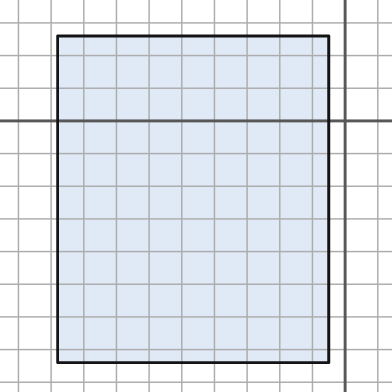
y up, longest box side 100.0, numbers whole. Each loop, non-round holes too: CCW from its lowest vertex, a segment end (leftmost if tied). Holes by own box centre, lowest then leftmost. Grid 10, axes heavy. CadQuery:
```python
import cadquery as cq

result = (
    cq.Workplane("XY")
    .moveTo(-88.0, -74.0)
    .lineTo(-5.0, -74.0)
    .lineTo(-5.0, 26.0)
    .lineTo(-88.0, 26.0)
    .close()
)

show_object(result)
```